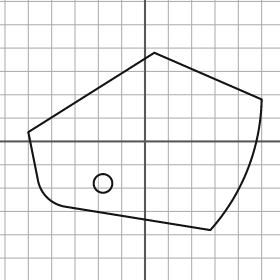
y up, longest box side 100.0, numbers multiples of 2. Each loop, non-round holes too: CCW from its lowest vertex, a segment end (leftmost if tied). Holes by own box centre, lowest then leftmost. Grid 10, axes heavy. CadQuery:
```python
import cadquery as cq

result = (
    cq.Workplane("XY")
    .moveTo(28.0, -38.0)
    .threePointArc((44.0, -12.0), (50.0, 18.0))
    .lineTo(4.0, 38.0)
    .lineTo(-50.0, 4.0)
    .lineTo(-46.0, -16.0)
    .threePointArc((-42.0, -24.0), (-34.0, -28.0))
    .close()
    .moveTo(-18.0, -18.0)
    .circle(4.0)
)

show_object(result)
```